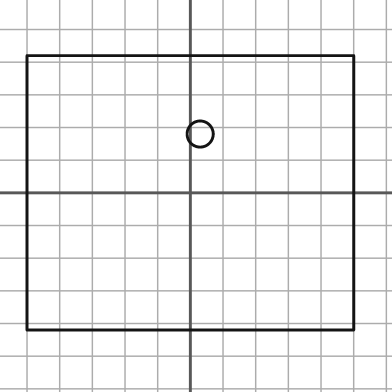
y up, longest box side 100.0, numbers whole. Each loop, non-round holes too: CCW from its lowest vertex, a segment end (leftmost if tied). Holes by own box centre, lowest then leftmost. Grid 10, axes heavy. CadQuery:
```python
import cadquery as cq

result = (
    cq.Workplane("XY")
    .moveTo(-50.0, -42.0)
    .lineTo(50.0, -42.0)
    .lineTo(50.0, 42.0)
    .lineTo(-50.0, 42.0)
    .close()
    .moveTo(3.0, 18.0)
    .circle(4.0)
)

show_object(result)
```